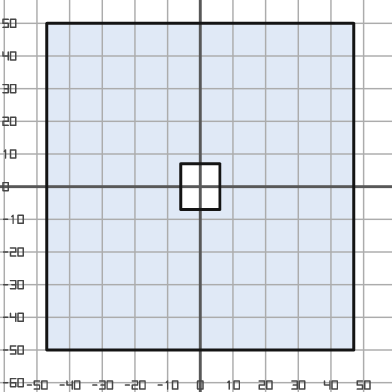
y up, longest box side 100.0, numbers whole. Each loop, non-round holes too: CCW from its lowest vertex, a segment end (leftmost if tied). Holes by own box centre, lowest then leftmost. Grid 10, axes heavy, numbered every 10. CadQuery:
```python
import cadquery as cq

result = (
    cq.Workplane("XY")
    .moveTo(-47.0, -50.0)
    .lineTo(47.0, -50.0)
    .lineTo(47.0, 50.0)
    .lineTo(-47.0, 50.0)
    .close()
    .moveTo(-6.0, -7.0)
    .lineTo(6.0, -7.0)
    .lineTo(6.0, 7.0)
    .lineTo(-6.0, 7.0)
    .close()
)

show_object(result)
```